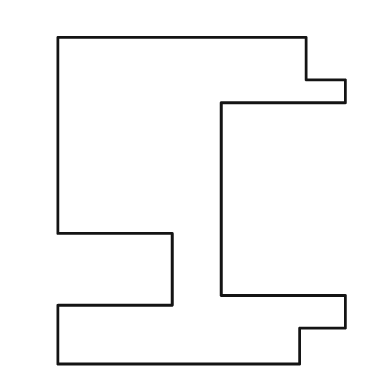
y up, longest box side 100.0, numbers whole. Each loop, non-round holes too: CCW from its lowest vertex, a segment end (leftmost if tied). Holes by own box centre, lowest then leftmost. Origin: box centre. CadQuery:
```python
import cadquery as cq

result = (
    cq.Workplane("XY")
    .moveTo(-44.0, -50.0)
    .lineTo(30.0, -50.0)
    .lineTo(30.0, -39.0)
    .lineTo(44.0, -39.0)
    .lineTo(44.0, -29.0)
    .lineTo(6.0, -29.0)
    .lineTo(6.0, 30.0)
    .lineTo(44.0, 30.0)
    .lineTo(44.0, 37.0)
    .lineTo(32.0, 37.0)
    .lineTo(32.0, 50.0)
    .lineTo(-44.0, 50.0)
    .lineTo(-44.0, -10.0)
    .lineTo(-9.0, -10.0)
    .lineTo(-9.0, -32.0)
    .lineTo(-44.0, -32.0)
    .close()
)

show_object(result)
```